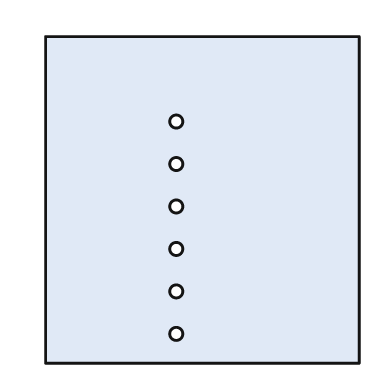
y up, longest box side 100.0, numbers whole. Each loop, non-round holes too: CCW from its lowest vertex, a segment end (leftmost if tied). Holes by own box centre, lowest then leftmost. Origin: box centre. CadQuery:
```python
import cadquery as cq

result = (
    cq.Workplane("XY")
    .moveTo(-48.0, -50.0)
    .lineTo(48.0, -50.0)
    .lineTo(48.0, 50.0)
    .lineTo(-48.0, 50.0)
    .close()
    .moveTo(-8.0, -41.0)
    .circle(2.0)
    .moveTo(-8.0, -28.0)
    .circle(2.0)
    .moveTo(-8.0, -15.0)
    .circle(2.0)
    .moveTo(-8.0, -2.0)
    .circle(2.0)
    .moveTo(-8.0, 11.0)
    .circle(2.0)
    .moveTo(-8.0, 24.0)
    .circle(2.0)
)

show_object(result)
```